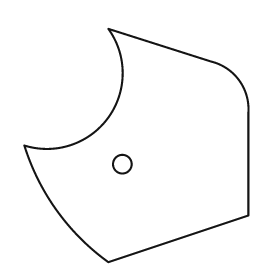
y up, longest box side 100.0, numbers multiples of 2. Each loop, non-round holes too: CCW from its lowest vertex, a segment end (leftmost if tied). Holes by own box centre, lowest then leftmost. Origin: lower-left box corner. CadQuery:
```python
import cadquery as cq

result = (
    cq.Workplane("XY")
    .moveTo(36.0, 0.0)
    .lineTo(96.0, 20.0)
    .lineTo(96.0, 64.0)
    .threePointArc((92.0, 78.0), (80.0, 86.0))
    .lineTo(36.0, 100.0)
    .threePointArc((36.0, 62.0), (0.0, 50.0))
    .threePointArc((14.0, 22.0), (36.0, 0.0))
    .close()
    .moveTo(42.0, 42.0)
    .circle(4.0)
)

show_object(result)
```